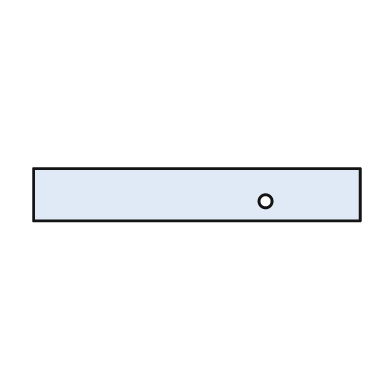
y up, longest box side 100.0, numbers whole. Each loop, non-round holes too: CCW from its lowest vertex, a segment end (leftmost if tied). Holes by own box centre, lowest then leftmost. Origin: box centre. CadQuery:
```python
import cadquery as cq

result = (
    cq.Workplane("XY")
    .moveTo(-50.0, -8.0)
    .lineTo(50.0, -8.0)
    .lineTo(50.0, 8.0)
    .lineTo(-50.0, 8.0)
    .close()
    .moveTo(21.0, -2.0)
    .circle(2.0)
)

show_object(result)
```